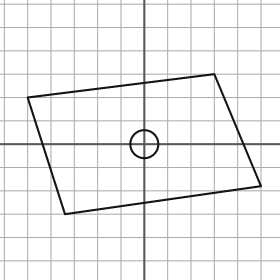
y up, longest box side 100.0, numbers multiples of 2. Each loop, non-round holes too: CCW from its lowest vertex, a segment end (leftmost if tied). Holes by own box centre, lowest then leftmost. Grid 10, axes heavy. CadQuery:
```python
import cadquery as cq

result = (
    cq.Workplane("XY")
    .moveTo(-34.0, -30.0)
    .lineTo(50.0, -18.0)
    .lineTo(30.0, 30.0)
    .lineTo(-50.0, 20.0)
    .close()
    .moveTo(0.0, 0.0)
    .circle(6.0)
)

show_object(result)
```